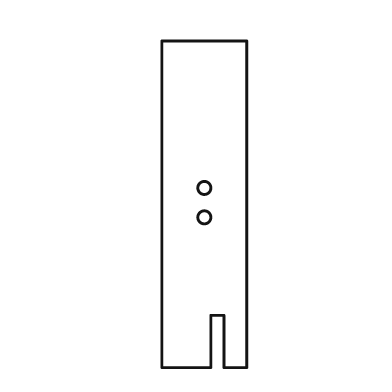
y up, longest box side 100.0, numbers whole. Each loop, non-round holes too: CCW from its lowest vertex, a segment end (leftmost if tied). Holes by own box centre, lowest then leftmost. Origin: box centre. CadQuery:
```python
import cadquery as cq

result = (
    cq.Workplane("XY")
    .moveTo(-13.0, -50.0)
    .lineTo(2.0, -50.0)
    .lineTo(2.0, -34.0)
    .lineTo(6.0, -34.0)
    .lineTo(6.0, -50.0)
    .lineTo(13.0, -50.0)
    .lineTo(13.0, 50.0)
    .lineTo(-13.0, 50.0)
    .close()
    .moveTo(0.0, -4.0)
    .circle(2.0)
    .moveTo(0.0, 5.0)
    .circle(2.0)
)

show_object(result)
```